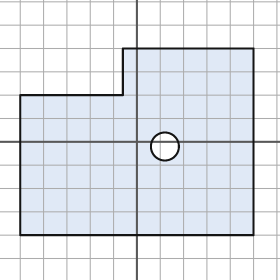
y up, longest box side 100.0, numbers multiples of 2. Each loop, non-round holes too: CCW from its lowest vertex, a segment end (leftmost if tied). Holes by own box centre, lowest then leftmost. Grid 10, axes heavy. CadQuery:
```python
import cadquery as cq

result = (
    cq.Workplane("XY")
    .moveTo(-50.0, -40.0)
    .lineTo(50.0, -40.0)
    .lineTo(50.0, 40.0)
    .lineTo(-6.0, 40.0)
    .lineTo(-6.0, 20.0)
    .lineTo(-50.0, 20.0)
    .close()
    .moveTo(12.0, -2.0)
    .circle(6.0)
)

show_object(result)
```